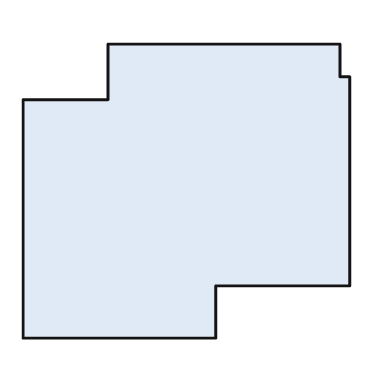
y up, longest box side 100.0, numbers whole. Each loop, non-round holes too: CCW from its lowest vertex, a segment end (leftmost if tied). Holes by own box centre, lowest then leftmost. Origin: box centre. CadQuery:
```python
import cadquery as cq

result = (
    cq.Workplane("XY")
    .moveTo(-50.0, -45.0)
    .lineTo(9.0, -45.0)
    .lineTo(9.0, -29.0)
    .lineTo(50.0, -29.0)
    .lineTo(50.0, 35.0)
    .lineTo(47.0, 35.0)
    .lineTo(47.0, 45.0)
    .lineTo(-24.0, 45.0)
    .lineTo(-24.0, 28.0)
    .lineTo(-50.0, 28.0)
    .close()
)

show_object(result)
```